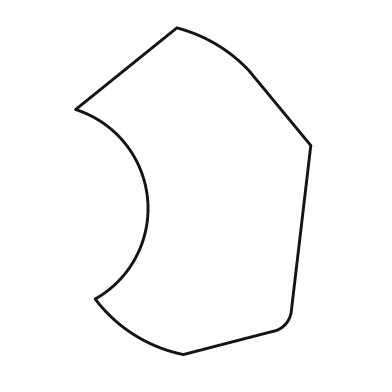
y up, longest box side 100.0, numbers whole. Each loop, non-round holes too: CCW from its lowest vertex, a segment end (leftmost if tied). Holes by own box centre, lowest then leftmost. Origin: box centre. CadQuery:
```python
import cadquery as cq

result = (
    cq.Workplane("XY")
    .moveTo(-3.0, -50.0)
    .lineTo(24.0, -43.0)
    .threePointArc((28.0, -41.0), (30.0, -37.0))
    .lineTo(36.0, 14.0)
    .lineTo(17.0, 37.0)
    .threePointArc((7.0, 45.0), (-5.0, 50.0))
    .lineTo(-36.0, 25.0)
    .threePointArc((-14.0, -2.0), (-30.0, -33.0))
    .threePointArc((-18.0, -44.0), (-3.0, -50.0))
    .close()
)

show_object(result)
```